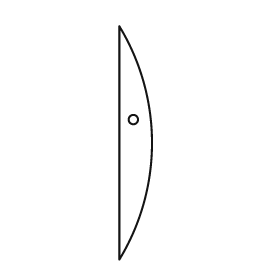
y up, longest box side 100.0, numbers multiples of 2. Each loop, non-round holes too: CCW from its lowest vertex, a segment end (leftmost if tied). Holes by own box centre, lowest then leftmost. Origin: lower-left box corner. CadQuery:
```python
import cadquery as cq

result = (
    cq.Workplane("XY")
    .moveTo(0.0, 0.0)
    .threePointArc((14.0, 50.0), (0.0, 100.0))
    .close()
    .moveTo(6.0, 60.0)
    .circle(2.0)
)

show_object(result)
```